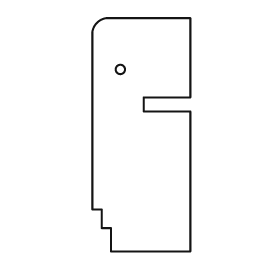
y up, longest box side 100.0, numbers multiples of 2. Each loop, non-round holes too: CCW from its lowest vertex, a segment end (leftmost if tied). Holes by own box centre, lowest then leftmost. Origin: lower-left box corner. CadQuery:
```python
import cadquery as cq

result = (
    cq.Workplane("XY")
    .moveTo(8.0, 0.0)
    .lineTo(42.0, 0.0)
    .lineTo(42.0, 60.0)
    .lineTo(22.0, 60.0)
    .lineTo(22.0, 66.0)
    .lineTo(42.0, 66.0)
    .lineTo(42.0, 100.0)
    .lineTo(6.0, 100.0)
    .threePointArc((2.0, 98.0), (0.0, 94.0))
    .lineTo(0.0, 18.0)
    .lineTo(4.0, 18.0)
    .lineTo(4.0, 10.0)
    .lineTo(8.0, 10.0)
    .close()
    .moveTo(12.0, 78.0)
    .circle(2.0)
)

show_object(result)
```